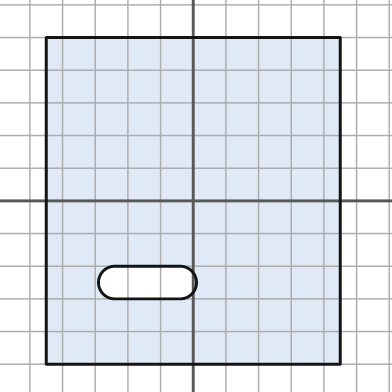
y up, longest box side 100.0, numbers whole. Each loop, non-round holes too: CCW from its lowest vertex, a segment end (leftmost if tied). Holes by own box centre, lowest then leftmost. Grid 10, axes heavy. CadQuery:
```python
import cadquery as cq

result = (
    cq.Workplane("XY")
    .moveTo(-45.0, -50.0)
    .lineTo(45.0, -50.0)
    .lineTo(45.0, 50.0)
    .lineTo(-45.0, 50.0)
    .close()
    .moveTo(-24.0, -30.0)
    .lineTo(-4.0, -30.0)
    .threePointArc((1.0, -25.0), (-4.0, -20.0))
    .lineTo(-24.0, -20.0)
    .threePointArc((-29.0, -25.0), (-24.0, -30.0))
    .close()
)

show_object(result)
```